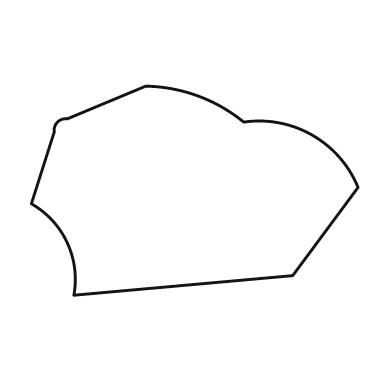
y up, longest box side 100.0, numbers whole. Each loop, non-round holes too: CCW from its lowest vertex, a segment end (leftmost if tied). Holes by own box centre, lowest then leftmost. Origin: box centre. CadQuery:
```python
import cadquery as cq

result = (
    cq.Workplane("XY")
    .moveTo(-37.0, -32.0)
    .lineTo(30.0, -26.0)
    .lineTo(50.0, 1.0)
    .threePointArc((36.0, 17.0), (15.0, 21.0))
    .threePointArc((1.0, 29.0), (-15.0, 32.0))
    .lineTo(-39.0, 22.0)
    .threePointArc((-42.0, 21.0), (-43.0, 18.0))
    .lineTo(-50.0, -4.0)
    .threePointArc((-39.0, -16.0), (-37.0, -32.0))
    .close()
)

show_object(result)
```